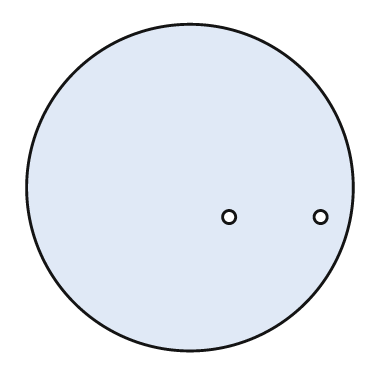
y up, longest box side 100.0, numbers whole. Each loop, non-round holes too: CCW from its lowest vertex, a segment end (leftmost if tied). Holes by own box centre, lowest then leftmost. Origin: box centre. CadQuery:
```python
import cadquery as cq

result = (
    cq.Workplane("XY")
    .moveTo(0.0, 0.0)
    .circle(50.0)
    .moveTo(12.0, -9.0)
    .circle(2.0)
    .moveTo(40.0, -9.0)
    .circle(2.0)
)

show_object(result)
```